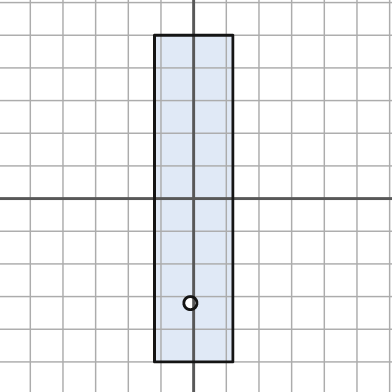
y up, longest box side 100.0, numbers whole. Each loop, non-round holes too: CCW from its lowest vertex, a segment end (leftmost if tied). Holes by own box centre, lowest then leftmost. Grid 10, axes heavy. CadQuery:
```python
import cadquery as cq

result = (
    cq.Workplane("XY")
    .moveTo(-12.0, -50.0)
    .lineTo(12.0, -50.0)
    .lineTo(12.0, 50.0)
    .lineTo(-12.0, 50.0)
    .close()
    .moveTo(-1.0, -32.0)
    .circle(2.0)
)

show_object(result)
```